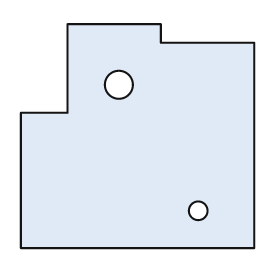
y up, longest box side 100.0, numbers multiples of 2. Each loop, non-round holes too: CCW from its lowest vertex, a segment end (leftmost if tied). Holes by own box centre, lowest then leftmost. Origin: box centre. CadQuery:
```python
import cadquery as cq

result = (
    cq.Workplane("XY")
    .moveTo(-50.0, -48.0)
    .lineTo(50.0, -48.0)
    .lineTo(50.0, 40.0)
    .lineTo(10.0, 40.0)
    .lineTo(10.0, 48.0)
    .lineTo(-30.0, 48.0)
    .lineTo(-30.0, 10.0)
    .lineTo(-50.0, 10.0)
    .close()
    .moveTo(26.0, -32.0)
    .circle(4.0)
    .moveTo(-8.0, 22.0)
    .circle(6.0)
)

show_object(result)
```